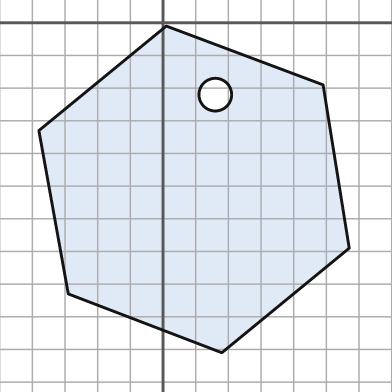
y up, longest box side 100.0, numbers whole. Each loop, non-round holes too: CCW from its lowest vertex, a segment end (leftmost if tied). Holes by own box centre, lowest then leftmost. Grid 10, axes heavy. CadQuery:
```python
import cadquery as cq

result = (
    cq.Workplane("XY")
    .moveTo(18.0, -101.0)
    .lineTo(57.0, -69.0)
    .lineTo(49.0, -19.0)
    .lineTo(1.0, -1.0)
    .lineTo(-38.0, -33.0)
    .lineTo(-29.0, -83.0)
    .close()
    .moveTo(16.0, -22.0)
    .circle(5.0)
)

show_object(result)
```